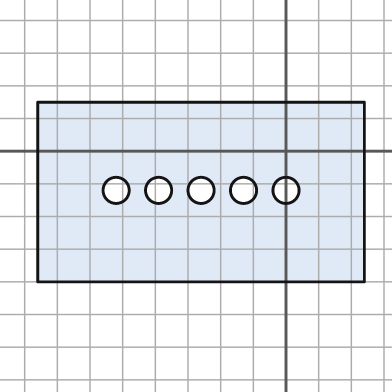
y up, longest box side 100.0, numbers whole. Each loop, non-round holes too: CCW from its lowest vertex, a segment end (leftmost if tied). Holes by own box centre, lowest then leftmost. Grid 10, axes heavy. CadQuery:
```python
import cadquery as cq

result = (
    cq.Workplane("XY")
    .moveTo(-76.0, -40.0)
    .lineTo(24.0, -40.0)
    .lineTo(24.0, 15.0)
    .lineTo(-76.0, 15.0)
    .close()
    .moveTo(-52.0, -12.0)
    .circle(4.0)
    .moveTo(-39.0, -12.0)
    .circle(4.0)
    .moveTo(-26.0, -12.0)
    .circle(4.0)
    .moveTo(-13.0, -12.0)
    .circle(4.0)
    .moveTo(0.0, -12.0)
    .circle(4.0)
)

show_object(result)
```